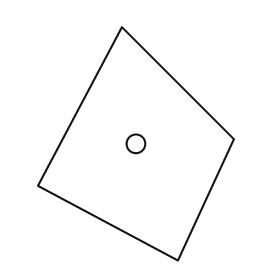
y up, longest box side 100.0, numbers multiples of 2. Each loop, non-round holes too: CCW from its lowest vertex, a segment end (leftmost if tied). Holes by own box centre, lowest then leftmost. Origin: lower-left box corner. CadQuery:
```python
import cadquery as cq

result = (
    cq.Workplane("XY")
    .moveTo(60.0, 0.0)
    .lineTo(84.0, 52.0)
    .lineTo(36.0, 100.0)
    .lineTo(0.0, 32.0)
    .close()
    .moveTo(42.0, 50.0)
    .circle(4.0)
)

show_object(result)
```